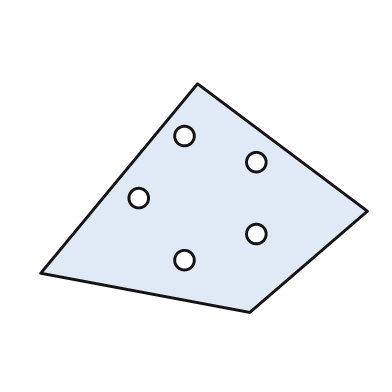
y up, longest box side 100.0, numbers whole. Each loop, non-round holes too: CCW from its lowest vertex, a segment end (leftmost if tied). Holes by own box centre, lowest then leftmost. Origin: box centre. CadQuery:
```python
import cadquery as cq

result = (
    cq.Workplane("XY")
    .moveTo(14.0, -35.0)
    .lineTo(50.0, -4.0)
    .lineTo(-2.0, 35.0)
    .lineTo(-50.0, -23.0)
    .close()
    .moveTo(-6.0, -19.0)
    .circle(3.0)
    .moveTo(16.0, -11.0)
    .circle(3.0)
    .moveTo(-20.0, 0.0)
    .circle(3.0)
    .moveTo(16.0, 11.0)
    .circle(3.0)
    .moveTo(-6.0, 19.0)
    .circle(3.0)
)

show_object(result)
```